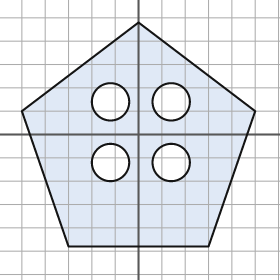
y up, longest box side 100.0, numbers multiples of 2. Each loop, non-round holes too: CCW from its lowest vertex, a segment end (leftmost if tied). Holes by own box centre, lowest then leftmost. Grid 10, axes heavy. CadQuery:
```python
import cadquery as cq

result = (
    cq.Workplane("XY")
    .moveTo(-30.0, -48.0)
    .lineTo(30.0, -48.0)
    .lineTo(50.0, 10.0)
    .lineTo(0.0, 48.0)
    .lineTo(-50.0, 10.0)
    .close()
    .moveTo(-12.0, -12.0)
    .circle(8.0)
    .moveTo(14.0, -12.0)
    .circle(8.0)
    .moveTo(-12.0, 14.0)
    .circle(8.0)
    .moveTo(14.0, 14.0)
    .circle(8.0)
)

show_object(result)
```